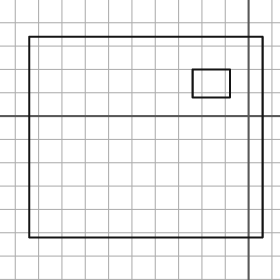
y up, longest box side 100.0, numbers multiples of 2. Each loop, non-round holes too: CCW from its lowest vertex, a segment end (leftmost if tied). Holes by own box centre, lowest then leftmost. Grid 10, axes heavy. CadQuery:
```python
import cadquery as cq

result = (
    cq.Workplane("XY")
    .moveTo(-94.0, -52.0)
    .lineTo(6.0, -52.0)
    .lineTo(6.0, 34.0)
    .lineTo(-94.0, 34.0)
    .close()
    .moveTo(-24.0, 8.0)
    .lineTo(-8.0, 8.0)
    .lineTo(-8.0, 20.0)
    .lineTo(-24.0, 20.0)
    .close()
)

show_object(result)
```